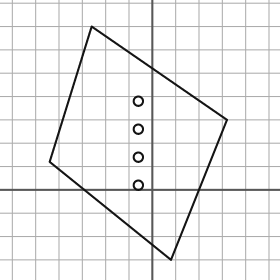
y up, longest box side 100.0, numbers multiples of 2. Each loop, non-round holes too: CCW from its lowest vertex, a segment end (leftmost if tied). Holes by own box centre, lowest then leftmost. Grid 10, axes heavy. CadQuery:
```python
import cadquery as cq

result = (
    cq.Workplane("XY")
    .moveTo(8.0, -30.0)
    .lineTo(32.0, 30.0)
    .lineTo(-26.0, 70.0)
    .lineTo(-44.0, 12.0)
    .close()
    .moveTo(-6.0, 2.0)
    .circle(2.0)
    .moveTo(-6.0, 14.0)
    .circle(2.0)
    .moveTo(-6.0, 26.0)
    .circle(2.0)
    .moveTo(-6.0, 38.0)
    .circle(2.0)
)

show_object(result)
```